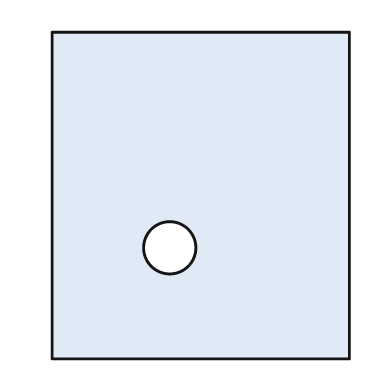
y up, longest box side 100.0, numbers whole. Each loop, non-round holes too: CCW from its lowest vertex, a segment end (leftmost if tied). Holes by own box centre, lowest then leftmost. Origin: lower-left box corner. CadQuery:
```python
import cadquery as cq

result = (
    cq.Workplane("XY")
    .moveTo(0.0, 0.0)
    .lineTo(91.0, 0.0)
    .lineTo(91.0, 100.0)
    .lineTo(0.0, 100.0)
    .close()
    .moveTo(36.0, 34.0)
    .circle(8.0)
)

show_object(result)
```